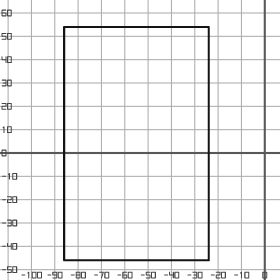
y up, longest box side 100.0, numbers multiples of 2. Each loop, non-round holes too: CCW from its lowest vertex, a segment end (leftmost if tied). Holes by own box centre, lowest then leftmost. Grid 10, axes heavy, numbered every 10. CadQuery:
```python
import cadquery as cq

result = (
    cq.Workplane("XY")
    .moveTo(-86.0, -46.0)
    .lineTo(-24.0, -46.0)
    .lineTo(-24.0, 54.0)
    .lineTo(-86.0, 54.0)
    .close()
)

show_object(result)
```